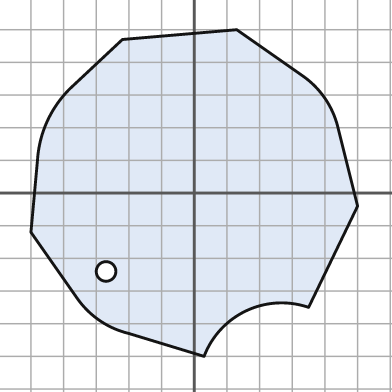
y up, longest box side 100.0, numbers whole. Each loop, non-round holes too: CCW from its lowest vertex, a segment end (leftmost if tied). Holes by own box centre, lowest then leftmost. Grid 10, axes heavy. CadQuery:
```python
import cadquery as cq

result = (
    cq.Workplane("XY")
    .moveTo(3.0, -50.0)
    .threePointArc((16.0, -36.0), (35.0, -35.0))
    .lineTo(50.0, -4.0)
    .lineTo(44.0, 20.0)
    .threePointArc((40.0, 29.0), (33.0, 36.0))
    .lineTo(13.0, 50.0)
    .lineTo(-22.0, 47.0)
    .lineTo(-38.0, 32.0)
    .threePointArc((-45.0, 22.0), (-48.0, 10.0))
    .lineTo(-50.0, -12.0)
    .lineTo(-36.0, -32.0)
    .threePointArc((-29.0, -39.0), (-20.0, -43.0))
    .close()
    .moveTo(-27.0, -24.0)
    .circle(3.0)
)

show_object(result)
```